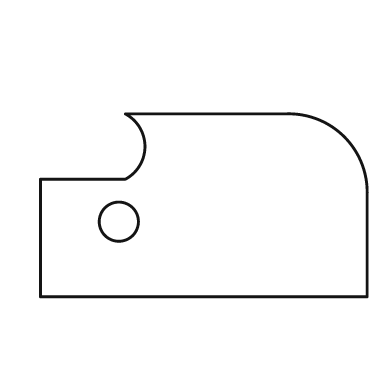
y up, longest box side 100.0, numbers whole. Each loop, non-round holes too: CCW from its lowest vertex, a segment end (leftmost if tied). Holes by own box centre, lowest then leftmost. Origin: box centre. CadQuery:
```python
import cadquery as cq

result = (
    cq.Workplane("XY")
    .moveTo(-50.0, -28.0)
    .lineTo(50.0, -28.0)
    .lineTo(50.0, 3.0)
    .threePointArc((43.0, 21.0), (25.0, 28.0))
    .lineTo(-24.0, 28.0)
    .threePointArc((-18.0, 18.0), (-24.0, 8.0))
    .lineTo(-50.0, 8.0)
    .close()
    .moveTo(-26.0, -5.0)
    .circle(6.0)
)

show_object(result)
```